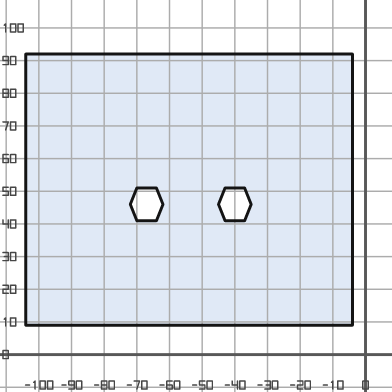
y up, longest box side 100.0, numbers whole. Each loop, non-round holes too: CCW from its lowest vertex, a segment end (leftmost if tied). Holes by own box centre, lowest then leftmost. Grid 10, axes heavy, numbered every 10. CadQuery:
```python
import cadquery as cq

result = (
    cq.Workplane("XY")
    .moveTo(-104.0, 9.0)
    .lineTo(-4.0, 9.0)
    .lineTo(-4.0, 92.0)
    .lineTo(-104.0, 92.0)
    .close()
    .moveTo(-70.0, 41.0)
    .lineTo(-64.0, 41.0)
    .lineTo(-62.0, 46.0)
    .lineTo(-64.0, 51.0)
    .lineTo(-70.0, 51.0)
    .lineTo(-72.0, 46.0)
    .close()
    .moveTo(-43.0, 41.0)
    .lineTo(-37.0, 41.0)
    .lineTo(-35.0, 46.0)
    .lineTo(-37.0, 51.0)
    .lineTo(-43.0, 51.0)
    .lineTo(-45.0, 46.0)
    .close()
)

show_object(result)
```